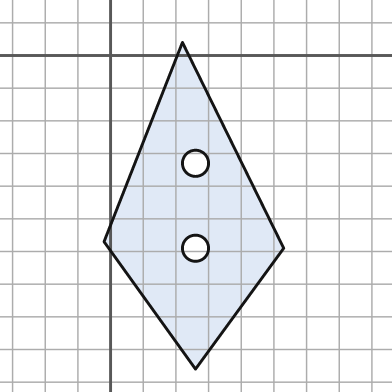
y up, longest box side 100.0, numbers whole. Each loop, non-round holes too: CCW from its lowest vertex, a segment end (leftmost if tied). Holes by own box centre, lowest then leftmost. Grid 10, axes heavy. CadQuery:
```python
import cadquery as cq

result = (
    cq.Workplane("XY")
    .moveTo(26.0, -96.0)
    .lineTo(53.0, -59.0)
    .lineTo(22.0, 4.0)
    .lineTo(-2.0, -57.0)
    .close()
    .moveTo(26.0, -59.0)
    .circle(4.0)
    .moveTo(26.0, -33.0)
    .circle(4.0)
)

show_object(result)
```